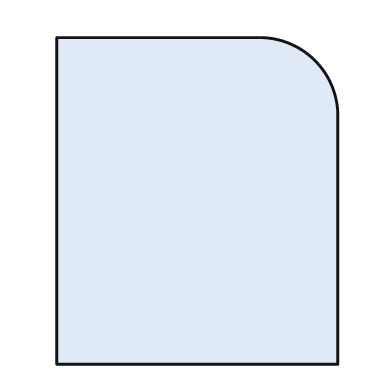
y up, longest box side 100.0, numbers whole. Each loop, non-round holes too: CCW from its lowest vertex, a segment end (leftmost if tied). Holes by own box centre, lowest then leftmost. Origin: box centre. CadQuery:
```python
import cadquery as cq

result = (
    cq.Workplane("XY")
    .moveTo(-43.0, -50.0)
    .lineTo(43.0, -50.0)
    .lineTo(43.0, 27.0)
    .threePointArc((36.0, 43.0), (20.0, 50.0))
    .lineTo(-43.0, 50.0)
    .close()
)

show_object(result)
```